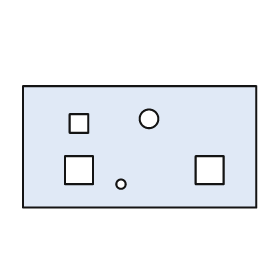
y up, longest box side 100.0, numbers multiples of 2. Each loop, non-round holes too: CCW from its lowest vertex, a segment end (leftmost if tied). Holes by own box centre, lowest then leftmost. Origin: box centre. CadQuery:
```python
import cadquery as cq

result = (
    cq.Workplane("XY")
    .moveTo(-50.0, -26.0)
    .lineTo(50.0, -26.0)
    .lineTo(50.0, 26.0)
    .lineTo(-50.0, 26.0)
    .close()
    .moveTo(-8.0, -16.0)
    .circle(2.0)
    .moveTo(-32.0, -16.0)
    .lineTo(-20.0, -16.0)
    .lineTo(-20.0, -4.0)
    .lineTo(-32.0, -4.0)
    .close()
    .moveTo(24.0, -16.0)
    .lineTo(36.0, -16.0)
    .lineTo(36.0, -4.0)
    .lineTo(24.0, -4.0)
    .close()
    .moveTo(-30.0, 6.0)
    .lineTo(-22.0, 6.0)
    .lineTo(-22.0, 14.0)
    .lineTo(-30.0, 14.0)
    .close()
    .moveTo(4.0, 12.0)
    .circle(4.0)
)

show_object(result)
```